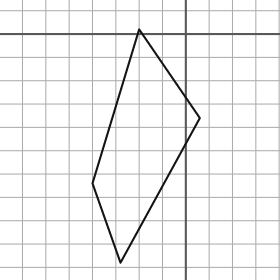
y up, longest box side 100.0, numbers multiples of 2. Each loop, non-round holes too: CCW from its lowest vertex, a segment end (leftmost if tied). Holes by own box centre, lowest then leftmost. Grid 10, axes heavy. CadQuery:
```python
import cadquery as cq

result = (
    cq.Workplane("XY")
    .moveTo(-28.0, -98.0)
    .lineTo(6.0, -36.0)
    .lineTo(-20.0, 2.0)
    .lineTo(-40.0, -64.0)
    .close()
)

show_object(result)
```